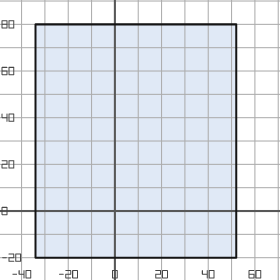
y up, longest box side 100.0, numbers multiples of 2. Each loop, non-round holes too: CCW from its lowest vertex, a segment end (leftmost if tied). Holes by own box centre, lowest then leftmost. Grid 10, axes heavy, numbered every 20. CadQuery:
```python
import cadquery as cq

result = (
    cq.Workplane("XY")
    .moveTo(-34.0, -20.0)
    .lineTo(52.0, -20.0)
    .lineTo(52.0, 80.0)
    .lineTo(-34.0, 80.0)
    .close()
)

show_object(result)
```